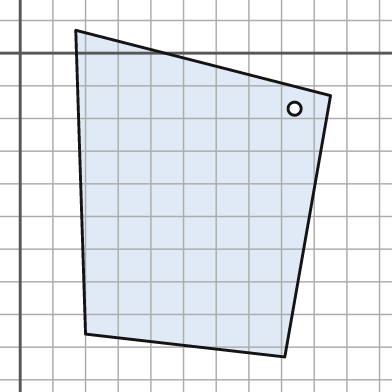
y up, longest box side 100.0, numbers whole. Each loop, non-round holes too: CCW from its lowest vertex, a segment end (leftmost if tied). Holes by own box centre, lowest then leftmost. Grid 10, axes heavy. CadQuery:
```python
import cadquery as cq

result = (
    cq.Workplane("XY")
    .moveTo(81.0, -93.0)
    .lineTo(95.0, -13.0)
    .lineTo(17.0, 7.0)
    .lineTo(20.0, -86.0)
    .close()
    .moveTo(84.0, -17.0)
    .circle(2.0)
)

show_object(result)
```